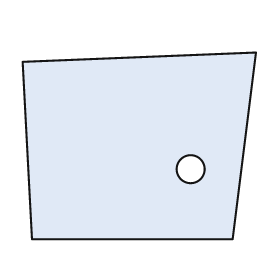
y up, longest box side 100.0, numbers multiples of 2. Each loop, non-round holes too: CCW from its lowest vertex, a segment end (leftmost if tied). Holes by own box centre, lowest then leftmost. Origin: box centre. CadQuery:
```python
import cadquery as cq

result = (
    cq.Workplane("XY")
    .moveTo(-46.0, -40.0)
    .lineTo(40.0, -40.0)
    .lineTo(50.0, 40.0)
    .lineTo(-50.0, 36.0)
    .close()
    .moveTo(22.0, -10.0)
    .circle(6.0)
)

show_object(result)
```